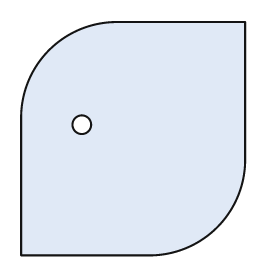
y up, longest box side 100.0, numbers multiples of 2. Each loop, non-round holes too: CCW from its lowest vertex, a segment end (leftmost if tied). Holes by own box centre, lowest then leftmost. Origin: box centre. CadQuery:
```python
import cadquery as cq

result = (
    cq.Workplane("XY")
    .moveTo(-48.0, -50.0)
    .lineTo(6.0, -50.0)
    .threePointArc((36.0, -38.0), (48.0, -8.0))
    .lineTo(48.0, 50.0)
    .lineTo(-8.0, 50.0)
    .threePointArc((-36.0, 38.0), (-48.0, 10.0))
    .close()
    .moveTo(-22.0, 6.0)
    .circle(4.0)
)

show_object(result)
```